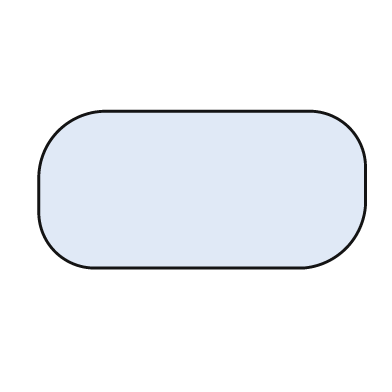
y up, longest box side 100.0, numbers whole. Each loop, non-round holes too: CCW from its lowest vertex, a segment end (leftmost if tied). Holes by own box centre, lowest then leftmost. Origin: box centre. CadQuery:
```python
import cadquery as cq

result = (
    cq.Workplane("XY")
    .moveTo(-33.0, -24.0)
    .lineTo(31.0, -24.0)
    .threePointArc((44.0, -18.0), (50.0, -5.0))
    .lineTo(50.0, 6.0)
    .threePointArc((45.0, 19.0), (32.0, 24.0))
    .lineTo(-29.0, 24.0)
    .threePointArc((-44.0, 18.0), (-50.0, 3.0))
    .lineTo(-50.0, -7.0)
    .threePointArc((-45.0, -19.0), (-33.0, -24.0))
    .close()
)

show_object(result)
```